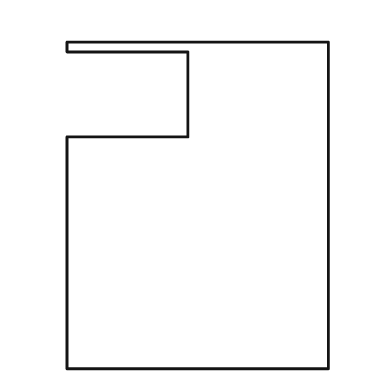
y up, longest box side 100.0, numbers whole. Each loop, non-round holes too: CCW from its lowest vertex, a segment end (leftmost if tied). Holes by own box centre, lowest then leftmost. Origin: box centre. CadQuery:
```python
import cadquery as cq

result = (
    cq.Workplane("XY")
    .moveTo(-40.0, -50.0)
    .lineTo(40.0, -50.0)
    .lineTo(40.0, 50.0)
    .lineTo(-40.0, 50.0)
    .lineTo(-40.0, 47.0)
    .lineTo(-3.0, 47.0)
    .lineTo(-3.0, 21.0)
    .lineTo(-40.0, 21.0)
    .close()
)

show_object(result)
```